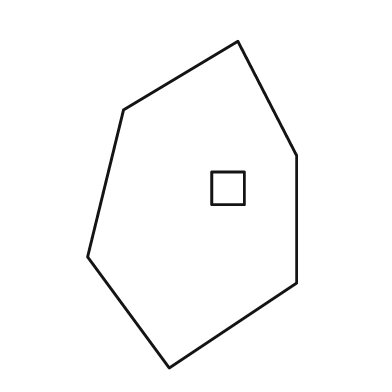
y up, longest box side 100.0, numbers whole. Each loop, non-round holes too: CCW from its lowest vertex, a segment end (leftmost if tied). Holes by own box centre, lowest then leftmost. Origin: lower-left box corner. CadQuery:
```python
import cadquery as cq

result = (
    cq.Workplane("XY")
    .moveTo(25.0, 0.0)
    .lineTo(64.0, 26.0)
    .lineTo(64.0, 65.0)
    .lineTo(46.0, 100.0)
    .lineTo(11.0, 79.0)
    .lineTo(0.0, 34.0)
    .close()
    .moveTo(38.0, 50.0)
    .lineTo(48.0, 50.0)
    .lineTo(48.0, 60.0)
    .lineTo(38.0, 60.0)
    .close()
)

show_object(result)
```